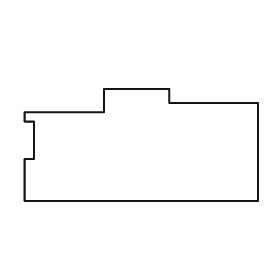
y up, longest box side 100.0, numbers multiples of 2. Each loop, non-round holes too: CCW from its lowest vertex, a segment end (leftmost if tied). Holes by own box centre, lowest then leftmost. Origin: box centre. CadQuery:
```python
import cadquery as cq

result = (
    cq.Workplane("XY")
    .moveTo(-50.0, -24.0)
    .lineTo(50.0, -24.0)
    .lineTo(50.0, 18.0)
    .lineTo(12.0, 18.0)
    .lineTo(12.0, 24.0)
    .lineTo(-16.0, 24.0)
    .lineTo(-16.0, 14.0)
    .lineTo(-50.0, 14.0)
    .lineTo(-50.0, 10.0)
    .lineTo(-46.0, 10.0)
    .lineTo(-46.0, -6.0)
    .lineTo(-50.0, -6.0)
    .close()
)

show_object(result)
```